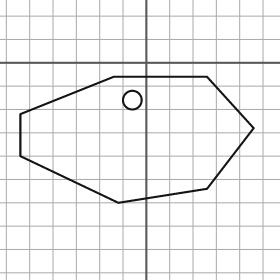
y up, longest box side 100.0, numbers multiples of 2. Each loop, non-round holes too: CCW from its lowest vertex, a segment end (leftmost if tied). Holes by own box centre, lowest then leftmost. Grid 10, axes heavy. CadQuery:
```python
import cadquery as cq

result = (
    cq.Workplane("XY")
    .moveTo(-12.0, -60.0)
    .lineTo(26.0, -54.0)
    .lineTo(46.0, -28.0)
    .lineTo(26.0, -6.0)
    .lineTo(-14.0, -6.0)
    .lineTo(-54.0, -22.0)
    .lineTo(-54.0, -40.0)
    .close()
    .moveTo(-6.0, -16.0)
    .circle(4.0)
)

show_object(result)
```